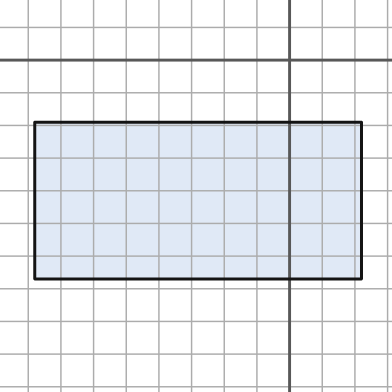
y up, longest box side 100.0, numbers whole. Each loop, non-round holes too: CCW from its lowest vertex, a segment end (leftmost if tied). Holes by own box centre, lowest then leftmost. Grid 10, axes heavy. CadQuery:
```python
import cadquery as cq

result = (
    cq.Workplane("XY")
    .moveTo(-78.0, -67.0)
    .lineTo(22.0, -67.0)
    .lineTo(22.0, -19.0)
    .lineTo(-78.0, -19.0)
    .close()
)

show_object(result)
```